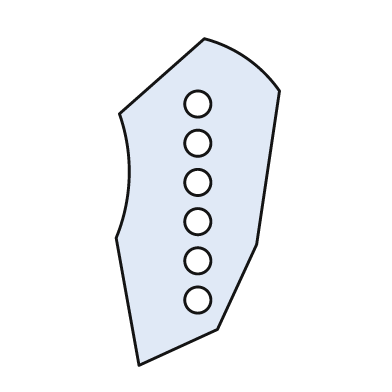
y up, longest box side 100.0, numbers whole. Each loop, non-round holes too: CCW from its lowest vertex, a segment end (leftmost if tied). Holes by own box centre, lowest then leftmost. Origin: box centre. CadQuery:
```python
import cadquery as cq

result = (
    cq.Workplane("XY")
    .moveTo(-18.0, -50.0)
    .lineTo(6.0, -39.0)
    .lineTo(18.0, -13.0)
    .lineTo(25.0, 34.0)
    .threePointArc((15.0, 44.0), (2.0, 50.0))
    .lineTo(-24.0, 27.0)
    .threePointArc((-21.0, 8.0), (-25.0, -11.0))
    .close()
    .moveTo(0.0, -30.0)
    .circle(4.0)
    .moveTo(0.0, -18.0)
    .circle(4.0)
    .moveTo(0.0, -6.0)
    .circle(4.0)
    .moveTo(0.0, 6.0)
    .circle(4.0)
    .moveTo(0.0, 18.0)
    .circle(4.0)
    .moveTo(0.0, 30.0)
    .circle(4.0)
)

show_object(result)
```